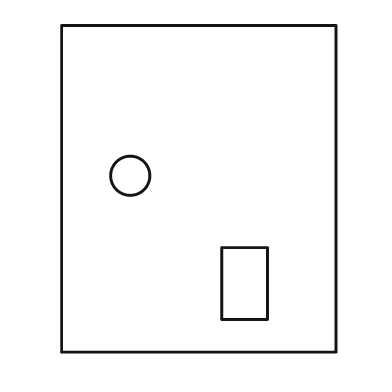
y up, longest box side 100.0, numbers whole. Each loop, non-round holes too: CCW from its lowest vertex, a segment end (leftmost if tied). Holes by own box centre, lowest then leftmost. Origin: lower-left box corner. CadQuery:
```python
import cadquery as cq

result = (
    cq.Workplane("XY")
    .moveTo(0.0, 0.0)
    .lineTo(84.0, 0.0)
    .lineTo(84.0, 100.0)
    .lineTo(0.0, 100.0)
    .close()
    .moveTo(49.0, 10.0)
    .lineTo(63.0, 10.0)
    .lineTo(63.0, 32.0)
    .lineTo(49.0, 32.0)
    .close()
    .moveTo(21.0, 54.0)
    .circle(6.0)
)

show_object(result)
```